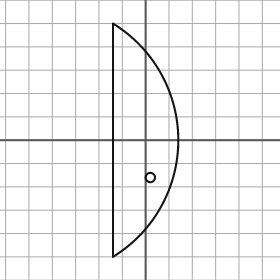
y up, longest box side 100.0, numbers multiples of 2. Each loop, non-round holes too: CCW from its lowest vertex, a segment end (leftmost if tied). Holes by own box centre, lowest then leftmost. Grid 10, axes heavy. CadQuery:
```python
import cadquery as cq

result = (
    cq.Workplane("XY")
    .moveTo(-14.0, -50.0)
    .threePointArc((14.0, 0.0), (-14.0, 50.0))
    .close()
    .moveTo(2.0, -16.0)
    .circle(2.0)
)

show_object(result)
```